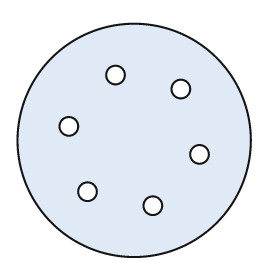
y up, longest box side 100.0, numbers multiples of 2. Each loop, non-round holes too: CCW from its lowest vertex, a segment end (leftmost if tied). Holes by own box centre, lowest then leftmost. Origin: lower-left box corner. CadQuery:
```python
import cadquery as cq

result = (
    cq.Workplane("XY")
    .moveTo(50.0, 50.0)
    .circle(50.0)
    .moveTo(58.0, 22.0)
    .circle(4.0)
    .moveTo(30.0, 28.0)
    .circle(4.0)
    .moveTo(78.0, 44.0)
    .circle(4.0)
    .moveTo(22.0, 56.0)
    .circle(4.0)
    .moveTo(70.0, 72.0)
    .circle(4.0)
    .moveTo(42.0, 78.0)
    .circle(4.0)
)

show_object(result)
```